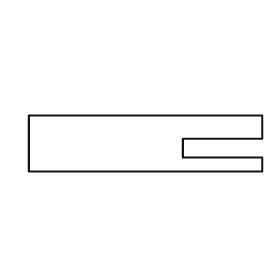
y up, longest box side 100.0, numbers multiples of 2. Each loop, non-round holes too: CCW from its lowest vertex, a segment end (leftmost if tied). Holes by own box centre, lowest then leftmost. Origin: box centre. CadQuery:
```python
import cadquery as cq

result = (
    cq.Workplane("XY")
    .moveTo(-50.0, -12.0)
    .lineTo(50.0, -12.0)
    .lineTo(50.0, -6.0)
    .lineTo(16.0, -6.0)
    .lineTo(16.0, 2.0)
    .lineTo(50.0, 2.0)
    .lineTo(50.0, 12.0)
    .lineTo(-50.0, 12.0)
    .close()
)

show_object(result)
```